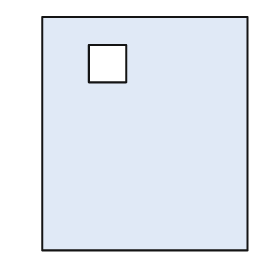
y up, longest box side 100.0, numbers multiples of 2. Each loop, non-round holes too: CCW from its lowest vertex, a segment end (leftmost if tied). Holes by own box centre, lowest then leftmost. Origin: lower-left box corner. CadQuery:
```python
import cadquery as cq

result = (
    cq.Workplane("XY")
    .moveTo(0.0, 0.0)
    .lineTo(88.0, 0.0)
    .lineTo(88.0, 100.0)
    .lineTo(0.0, 100.0)
    .close()
    .moveTo(20.0, 72.0)
    .lineTo(36.0, 72.0)
    .lineTo(36.0, 88.0)
    .lineTo(20.0, 88.0)
    .close()
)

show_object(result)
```